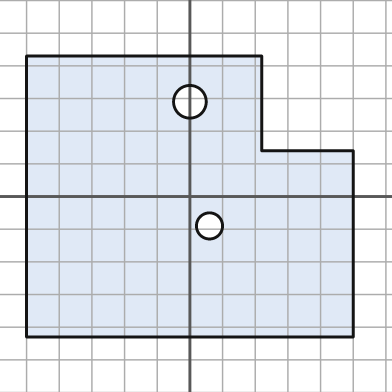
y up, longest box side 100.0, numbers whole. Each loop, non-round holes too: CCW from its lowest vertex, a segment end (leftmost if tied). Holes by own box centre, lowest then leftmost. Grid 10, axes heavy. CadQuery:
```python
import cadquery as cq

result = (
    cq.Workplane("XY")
    .moveTo(-50.0, -43.0)
    .lineTo(50.0, -43.0)
    .lineTo(50.0, 14.0)
    .lineTo(22.0, 14.0)
    .lineTo(22.0, 43.0)
    .lineTo(-50.0, 43.0)
    .close()
    .moveTo(6.0, -9.0)
    .circle(4.0)
    .moveTo(0.0, 29.0)
    .circle(5.0)
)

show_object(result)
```